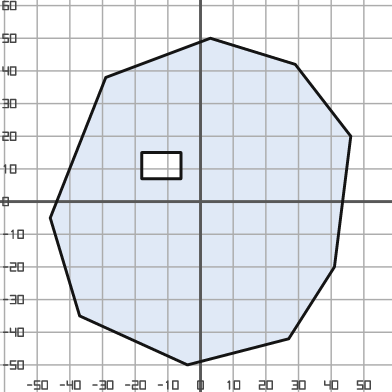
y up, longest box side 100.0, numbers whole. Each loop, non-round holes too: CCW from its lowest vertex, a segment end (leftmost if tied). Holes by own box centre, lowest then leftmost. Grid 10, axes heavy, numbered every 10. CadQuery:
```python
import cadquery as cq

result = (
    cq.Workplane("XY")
    .moveTo(-4.0, -50.0)
    .lineTo(27.0, -42.0)
    .lineTo(41.0, -20.0)
    .lineTo(46.0, 20.0)
    .lineTo(29.0, 42.0)
    .lineTo(3.0, 50.0)
    .lineTo(-29.0, 38.0)
    .lineTo(-46.0, -5.0)
    .lineTo(-37.0, -35.0)
    .close()
    .moveTo(-18.0, 7.0)
    .lineTo(-6.0, 7.0)
    .lineTo(-6.0, 15.0)
    .lineTo(-18.0, 15.0)
    .close()
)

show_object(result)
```